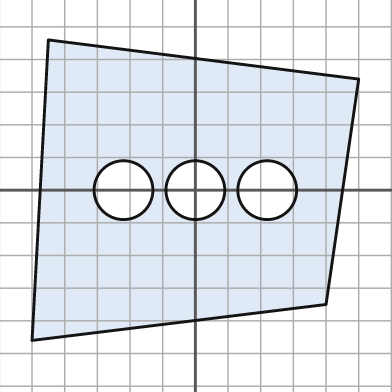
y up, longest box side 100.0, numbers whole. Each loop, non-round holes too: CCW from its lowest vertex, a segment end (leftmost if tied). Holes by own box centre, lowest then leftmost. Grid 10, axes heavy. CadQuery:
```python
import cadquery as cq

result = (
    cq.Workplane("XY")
    .moveTo(-50.0, -46.0)
    .lineTo(40.0, -35.0)
    .lineTo(50.0, 34.0)
    .lineTo(-45.0, 46.0)
    .close()
    .moveTo(-22.0, 0.0)
    .circle(9.0)
    .moveTo(0.0, 0.0)
    .circle(9.0)
    .moveTo(22.0, 0.0)
    .circle(9.0)
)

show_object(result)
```